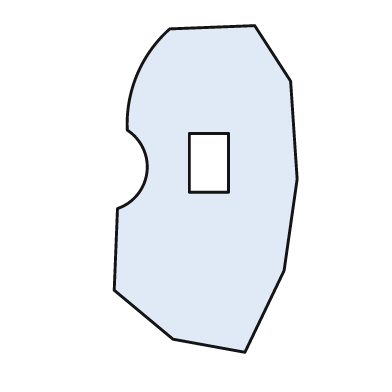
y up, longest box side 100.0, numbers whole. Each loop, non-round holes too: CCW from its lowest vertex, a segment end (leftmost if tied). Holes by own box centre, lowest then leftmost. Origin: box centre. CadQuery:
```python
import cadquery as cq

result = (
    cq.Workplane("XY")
    .moveTo(12.0, -50.0)
    .lineTo(24.0, -25.0)
    .lineTo(28.0, 3.0)
    .lineTo(26.0, 33.0)
    .lineTo(15.0, 50.0)
    .lineTo(-11.0, 49.0)
    .threePointArc((-21.0, 35.0), (-24.0, 18.0))
    .threePointArc((-18.0, 5.0), (-27.0, -6.0))
    .lineTo(-28.0, -31.0)
    .lineTo(-10.0, -46.0)
    .close()
    .moveTo(-5.0, -1.0)
    .lineTo(7.0, -1.0)
    .lineTo(7.0, 17.0)
    .lineTo(-5.0, 17.0)
    .close()
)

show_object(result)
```